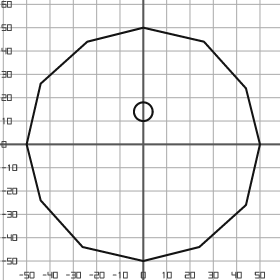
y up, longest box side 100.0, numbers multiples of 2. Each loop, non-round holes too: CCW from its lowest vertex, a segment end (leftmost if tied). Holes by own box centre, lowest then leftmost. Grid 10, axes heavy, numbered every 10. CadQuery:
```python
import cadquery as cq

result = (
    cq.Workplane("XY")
    .moveTo(0.0, -50.0)
    .lineTo(24.0, -44.0)
    .lineTo(44.0, -26.0)
    .lineTo(50.0, 0.0)
    .lineTo(44.0, 24.0)
    .lineTo(26.0, 44.0)
    .lineTo(0.0, 50.0)
    .lineTo(-24.0, 44.0)
    .lineTo(-44.0, 26.0)
    .lineTo(-50.0, 0.0)
    .lineTo(-44.0, -24.0)
    .lineTo(-26.0, -44.0)
    .close()
    .moveTo(0.0, 14.0)
    .circle(4.0)
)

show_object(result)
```